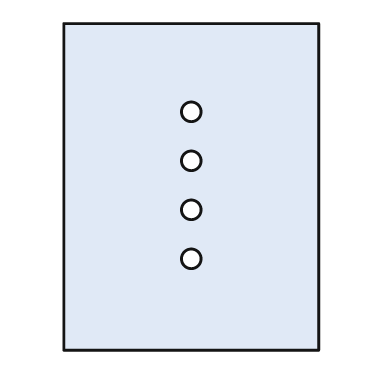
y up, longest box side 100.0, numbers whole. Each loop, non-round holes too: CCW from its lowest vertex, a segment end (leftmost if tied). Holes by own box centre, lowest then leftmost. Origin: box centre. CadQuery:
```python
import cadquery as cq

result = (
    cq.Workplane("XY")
    .moveTo(-39.0, -50.0)
    .lineTo(39.0, -50.0)
    .lineTo(39.0, 50.0)
    .lineTo(-39.0, 50.0)
    .close()
    .moveTo(0.0, -22.0)
    .circle(3.0)
    .moveTo(0.0, -7.0)
    .circle(3.0)
    .moveTo(0.0, 8.0)
    .circle(3.0)
    .moveTo(0.0, 23.0)
    .circle(3.0)
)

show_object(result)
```